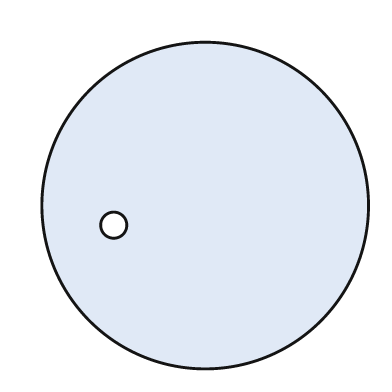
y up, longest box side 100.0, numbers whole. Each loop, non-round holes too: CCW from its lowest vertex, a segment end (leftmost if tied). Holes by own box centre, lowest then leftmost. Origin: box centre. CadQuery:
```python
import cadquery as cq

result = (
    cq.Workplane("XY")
    .moveTo(0.0, 0.0)
    .circle(50.0)
    .moveTo(-28.0, -6.0)
    .circle(4.0)
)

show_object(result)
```